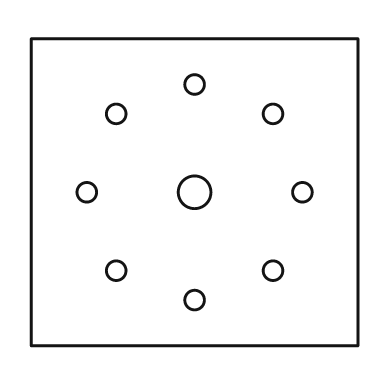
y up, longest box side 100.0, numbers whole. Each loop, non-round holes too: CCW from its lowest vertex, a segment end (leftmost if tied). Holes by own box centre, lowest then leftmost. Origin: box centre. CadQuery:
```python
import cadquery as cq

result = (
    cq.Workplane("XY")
    .moveTo(-50.0, -47.0)
    .lineTo(50.0, -47.0)
    .lineTo(50.0, 47.0)
    .lineTo(-50.0, 47.0)
    .close()
    .moveTo(0.0, -33.0)
    .circle(3.0)
    .moveTo(-24.0, -24.0)
    .circle(3.0)
    .moveTo(24.0, -24.0)
    .circle(3.0)
    .moveTo(-33.0, 0.0)
    .circle(3.0)
    .moveTo(0.0, 0.0)
    .circle(5.0)
    .moveTo(33.0, 0.0)
    .circle(3.0)
    .moveTo(-24.0, 24.0)
    .circle(3.0)
    .moveTo(24.0, 24.0)
    .circle(3.0)
    .moveTo(0.0, 33.0)
    .circle(3.0)
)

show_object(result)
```